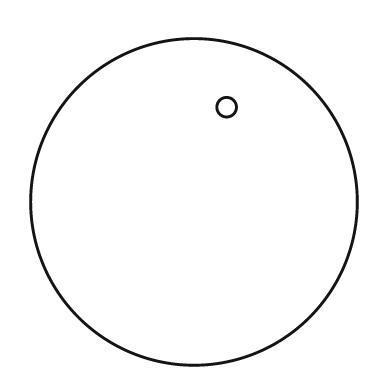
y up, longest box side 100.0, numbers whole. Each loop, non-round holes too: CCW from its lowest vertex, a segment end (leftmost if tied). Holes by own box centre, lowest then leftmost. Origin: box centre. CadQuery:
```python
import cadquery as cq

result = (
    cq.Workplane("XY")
    .moveTo(0.0, 0.0)
    .circle(50.0)
    .moveTo(10.0, 29.0)
    .circle(3.0)
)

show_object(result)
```